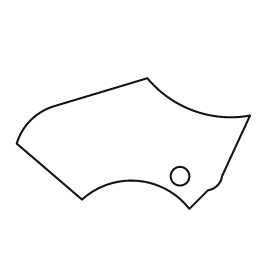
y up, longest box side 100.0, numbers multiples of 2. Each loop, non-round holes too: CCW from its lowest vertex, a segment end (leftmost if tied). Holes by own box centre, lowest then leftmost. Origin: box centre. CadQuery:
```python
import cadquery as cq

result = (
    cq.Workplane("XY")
    .moveTo(24.0, -28.0)
    .lineTo(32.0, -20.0)
    .threePointArc((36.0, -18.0), (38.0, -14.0))
    .lineTo(50.0, 12.0)
    .threePointArc((26.0, 14.0), (6.0, 28.0))
    .lineTo(-34.0, 16.0)
    .threePointArc((-44.0, 10.0), (-50.0, 0.0))
    .lineTo(-22.0, -24.0)
    .threePointArc((2.0, -16.0), (24.0, -28.0))
    .close()
    .moveTo(20.0, -14.0)
    .circle(4.0)
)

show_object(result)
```